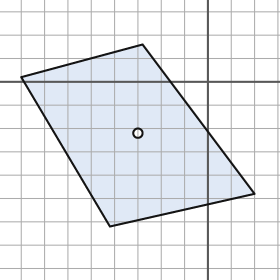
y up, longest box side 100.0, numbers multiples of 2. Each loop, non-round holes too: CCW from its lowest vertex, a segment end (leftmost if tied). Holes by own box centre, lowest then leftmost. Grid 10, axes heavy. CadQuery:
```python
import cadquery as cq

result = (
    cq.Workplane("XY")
    .moveTo(-42.0, -62.0)
    .lineTo(20.0, -48.0)
    .lineTo(-28.0, 16.0)
    .lineTo(-80.0, 2.0)
    .close()
    .moveTo(-30.0, -22.0)
    .circle(2.0)
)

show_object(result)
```